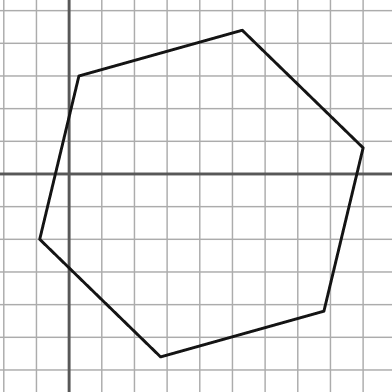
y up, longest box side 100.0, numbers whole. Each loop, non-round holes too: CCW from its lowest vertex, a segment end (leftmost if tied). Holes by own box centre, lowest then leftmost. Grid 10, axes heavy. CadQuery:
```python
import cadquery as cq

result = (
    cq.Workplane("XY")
    .moveTo(28.0, -56.0)
    .lineTo(78.0, -42.0)
    .lineTo(90.0, 8.0)
    .lineTo(53.0, 44.0)
    .lineTo(3.0, 30.0)
    .lineTo(-9.0, -20.0)
    .close()
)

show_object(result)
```